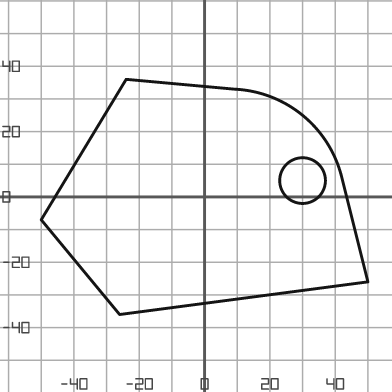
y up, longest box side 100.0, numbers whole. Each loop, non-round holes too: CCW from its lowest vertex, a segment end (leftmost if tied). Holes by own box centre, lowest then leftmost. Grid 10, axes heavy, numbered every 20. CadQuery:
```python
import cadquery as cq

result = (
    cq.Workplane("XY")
    .moveTo(-26.0, -36.0)
    .lineTo(50.0, -26.0)
    .lineTo(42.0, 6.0)
    .threePointArc((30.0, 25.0), (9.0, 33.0))
    .lineTo(-24.0, 36.0)
    .lineTo(-50.0, -7.0)
    .close()
    .moveTo(30.0, 5.0)
    .circle(7.0)
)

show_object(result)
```